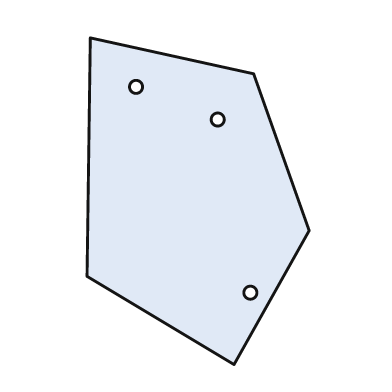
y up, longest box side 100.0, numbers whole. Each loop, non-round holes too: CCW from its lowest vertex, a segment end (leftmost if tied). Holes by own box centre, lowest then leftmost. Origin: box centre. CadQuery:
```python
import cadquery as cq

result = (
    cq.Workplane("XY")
    .moveTo(11.0, -50.0)
    .lineTo(34.0, -9.0)
    .lineTo(17.0, 39.0)
    .lineTo(-33.0, 50.0)
    .lineTo(-34.0, -23.0)
    .close()
    .moveTo(16.0, -28.0)
    .circle(2.0)
    .moveTo(6.0, 25.0)
    .circle(2.0)
    .moveTo(-19.0, 35.0)
    .circle(2.0)
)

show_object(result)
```